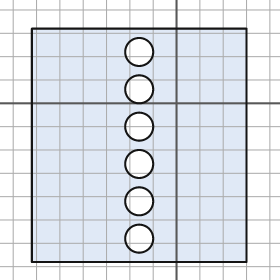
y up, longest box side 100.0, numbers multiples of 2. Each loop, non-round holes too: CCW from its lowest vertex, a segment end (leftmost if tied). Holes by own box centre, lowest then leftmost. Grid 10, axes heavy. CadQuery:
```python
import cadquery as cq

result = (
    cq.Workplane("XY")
    .moveTo(-62.0, -68.0)
    .lineTo(30.0, -68.0)
    .lineTo(30.0, 32.0)
    .lineTo(-62.0, 32.0)
    .close()
    .moveTo(-16.0, -58.0)
    .circle(6.0)
    .moveTo(-16.0, -42.0)
    .circle(6.0)
    .moveTo(-16.0, -26.0)
    .circle(6.0)
    .moveTo(-16.0, -10.0)
    .circle(6.0)
    .moveTo(-16.0, 6.0)
    .circle(6.0)
    .moveTo(-16.0, 22.0)
    .circle(6.0)
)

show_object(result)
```